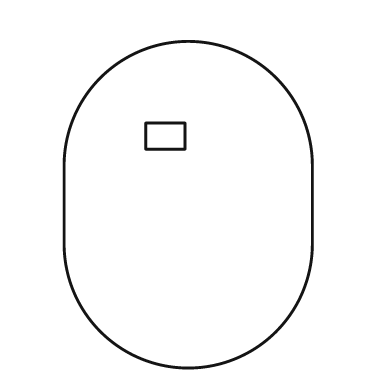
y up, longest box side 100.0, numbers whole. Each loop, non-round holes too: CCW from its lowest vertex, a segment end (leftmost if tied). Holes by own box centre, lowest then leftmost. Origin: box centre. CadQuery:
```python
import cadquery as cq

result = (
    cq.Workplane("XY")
    .moveTo(-38.0, -12.0)
    .threePointArc((0.0, -50.0), (38.0, -12.0))
    .lineTo(38.0, 12.0)
    .threePointArc((0.0, 50.0), (-38.0, 12.0))
    .close()
    .moveTo(-13.0, 17.0)
    .lineTo(-1.0, 17.0)
    .lineTo(-1.0, 25.0)
    .lineTo(-13.0, 25.0)
    .close()
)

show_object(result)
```